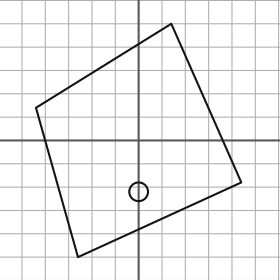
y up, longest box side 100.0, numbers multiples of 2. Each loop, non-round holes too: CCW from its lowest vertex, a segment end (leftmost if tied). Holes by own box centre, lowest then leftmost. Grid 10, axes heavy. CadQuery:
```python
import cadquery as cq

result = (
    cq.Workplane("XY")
    .moveTo(-26.0, -50.0)
    .lineTo(44.0, -18.0)
    .lineTo(14.0, 50.0)
    .lineTo(-44.0, 14.0)
    .close()
    .moveTo(0.0, -22.0)
    .circle(4.0)
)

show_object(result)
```